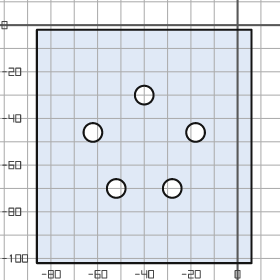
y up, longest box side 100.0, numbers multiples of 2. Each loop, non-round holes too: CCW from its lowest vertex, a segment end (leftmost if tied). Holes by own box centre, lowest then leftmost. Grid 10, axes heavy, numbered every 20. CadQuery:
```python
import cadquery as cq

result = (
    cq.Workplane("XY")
    .moveTo(-86.0, -102.0)
    .lineTo(6.0, -102.0)
    .lineTo(6.0, -2.0)
    .lineTo(-86.0, -2.0)
    .close()
    .moveTo(-52.0, -70.0)
    .circle(4.0)
    .moveTo(-28.0, -70.0)
    .circle(4.0)
    .moveTo(-62.0, -46.0)
    .circle(4.0)
    .moveTo(-18.0, -46.0)
    .circle(4.0)
    .moveTo(-40.0, -30.0)
    .circle(4.0)
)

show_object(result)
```